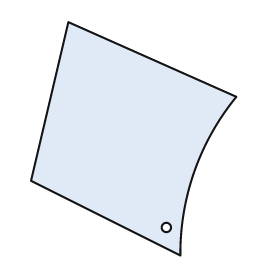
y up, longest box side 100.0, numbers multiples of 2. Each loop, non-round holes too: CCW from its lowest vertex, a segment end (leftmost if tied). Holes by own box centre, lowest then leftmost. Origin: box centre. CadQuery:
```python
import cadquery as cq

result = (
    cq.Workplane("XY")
    .moveTo(20.0, -50.0)
    .threePointArc((26.0, -14.0), (44.0, 18.0))
    .lineTo(-28.0, 50.0)
    .lineTo(-44.0, -18.0)
    .close()
    .moveTo(14.0, -38.0)
    .circle(2.0)
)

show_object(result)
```